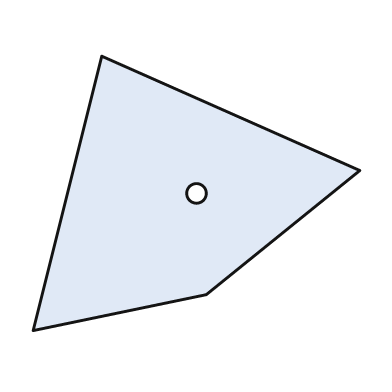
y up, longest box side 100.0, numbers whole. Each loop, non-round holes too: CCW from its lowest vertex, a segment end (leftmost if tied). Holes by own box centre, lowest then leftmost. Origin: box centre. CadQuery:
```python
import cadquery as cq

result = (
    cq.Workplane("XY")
    .moveTo(-50.0, -42.0)
    .lineTo(3.0, -31.0)
    .lineTo(50.0, 7.0)
    .lineTo(-29.0, 42.0)
    .close()
    .moveTo(0.0, 0.0)
    .circle(3.0)
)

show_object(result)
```